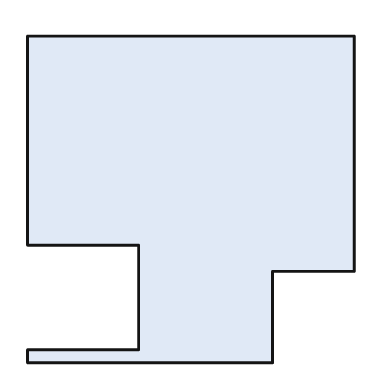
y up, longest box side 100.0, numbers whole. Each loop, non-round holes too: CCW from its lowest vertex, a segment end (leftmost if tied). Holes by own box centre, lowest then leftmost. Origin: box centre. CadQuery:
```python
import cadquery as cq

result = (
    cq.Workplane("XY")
    .moveTo(-50.0, -50.0)
    .lineTo(25.0, -50.0)
    .lineTo(25.0, -22.0)
    .lineTo(50.0, -22.0)
    .lineTo(50.0, 50.0)
    .lineTo(-50.0, 50.0)
    .lineTo(-50.0, -14.0)
    .lineTo(-16.0, -14.0)
    .lineTo(-16.0, -46.0)
    .lineTo(-50.0, -46.0)
    .close()
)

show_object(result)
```